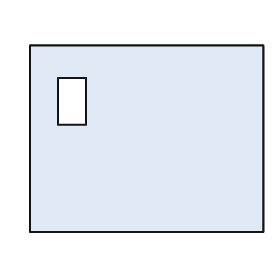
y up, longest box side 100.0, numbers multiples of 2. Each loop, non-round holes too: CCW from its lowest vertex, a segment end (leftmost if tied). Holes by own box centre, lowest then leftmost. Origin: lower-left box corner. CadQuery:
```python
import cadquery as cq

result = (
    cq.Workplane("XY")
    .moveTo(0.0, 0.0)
    .lineTo(100.0, 0.0)
    .lineTo(100.0, 80.0)
    .lineTo(0.0, 80.0)
    .close()
    .moveTo(12.0, 46.0)
    .lineTo(24.0, 46.0)
    .lineTo(24.0, 66.0)
    .lineTo(12.0, 66.0)
    .close()
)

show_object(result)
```